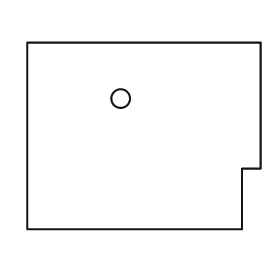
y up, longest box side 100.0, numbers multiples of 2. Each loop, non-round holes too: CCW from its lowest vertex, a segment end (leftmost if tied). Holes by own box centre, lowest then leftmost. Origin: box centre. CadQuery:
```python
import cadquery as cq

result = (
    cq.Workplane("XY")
    .moveTo(-50.0, -40.0)
    .lineTo(42.0, -40.0)
    .lineTo(42.0, -14.0)
    .lineTo(50.0, -14.0)
    .lineTo(50.0, 40.0)
    .lineTo(-50.0, 40.0)
    .close()
    .moveTo(-10.0, 16.0)
    .circle(4.0)
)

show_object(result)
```